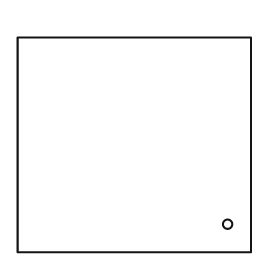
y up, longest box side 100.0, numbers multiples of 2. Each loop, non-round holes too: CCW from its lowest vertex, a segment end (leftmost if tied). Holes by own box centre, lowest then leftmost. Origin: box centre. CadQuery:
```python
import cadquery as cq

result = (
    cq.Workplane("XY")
    .moveTo(-50.0, -46.0)
    .lineTo(50.0, -46.0)
    .lineTo(50.0, 46.0)
    .lineTo(-50.0, 46.0)
    .close()
    .moveTo(40.0, -34.0)
    .circle(2.0)
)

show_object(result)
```